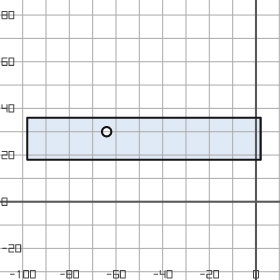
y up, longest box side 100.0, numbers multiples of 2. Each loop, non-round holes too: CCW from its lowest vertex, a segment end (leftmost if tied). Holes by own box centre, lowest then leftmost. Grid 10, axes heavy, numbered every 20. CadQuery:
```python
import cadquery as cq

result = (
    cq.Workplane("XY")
    .moveTo(-98.0, 18.0)
    .lineTo(2.0, 18.0)
    .lineTo(2.0, 36.0)
    .lineTo(-98.0, 36.0)
    .close()
    .moveTo(-64.0, 30.0)
    .circle(2.0)
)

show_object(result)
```